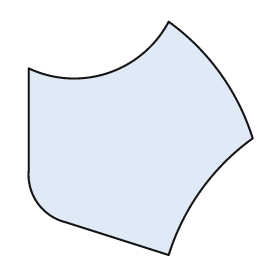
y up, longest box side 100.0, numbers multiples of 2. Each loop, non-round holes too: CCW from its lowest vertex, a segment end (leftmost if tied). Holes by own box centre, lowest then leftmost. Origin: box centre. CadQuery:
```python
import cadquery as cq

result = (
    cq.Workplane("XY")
    .moveTo(12.0, -50.0)
    .threePointArc((26.0, -22.0), (48.0, 0.0))
    .threePointArc((34.0, 28.0), (12.0, 50.0))
    .threePointArc((-14.0, 28.0), (-48.0, 30.0))
    .lineTo(-48.0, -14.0)
    .threePointArc((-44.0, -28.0), (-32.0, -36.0))
    .close()
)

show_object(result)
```